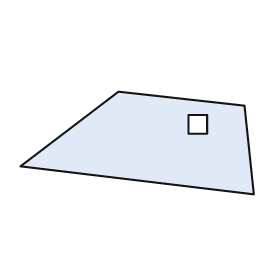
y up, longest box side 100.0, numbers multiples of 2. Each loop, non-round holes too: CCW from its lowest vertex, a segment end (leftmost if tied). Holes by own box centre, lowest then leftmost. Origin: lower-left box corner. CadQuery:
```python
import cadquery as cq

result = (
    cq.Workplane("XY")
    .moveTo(100.0, 0.0)
    .lineTo(96.0, 38.0)
    .lineTo(42.0, 44.0)
    .lineTo(0.0, 12.0)
    .close()
    .moveTo(72.0, 26.0)
    .lineTo(80.0, 26.0)
    .lineTo(80.0, 34.0)
    .lineTo(72.0, 34.0)
    .close()
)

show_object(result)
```